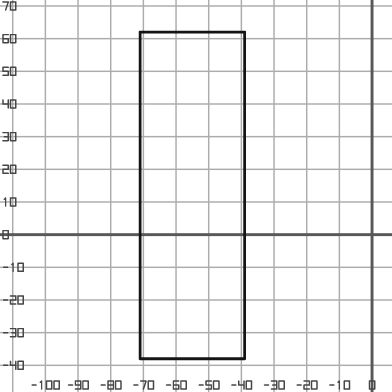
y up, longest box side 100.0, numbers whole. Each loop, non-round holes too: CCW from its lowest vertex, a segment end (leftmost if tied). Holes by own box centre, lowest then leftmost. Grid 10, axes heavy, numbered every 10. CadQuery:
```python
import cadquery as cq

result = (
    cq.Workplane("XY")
    .moveTo(-71.0, -38.0)
    .lineTo(-39.0, -38.0)
    .lineTo(-39.0, 62.0)
    .lineTo(-71.0, 62.0)
    .close()
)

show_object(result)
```